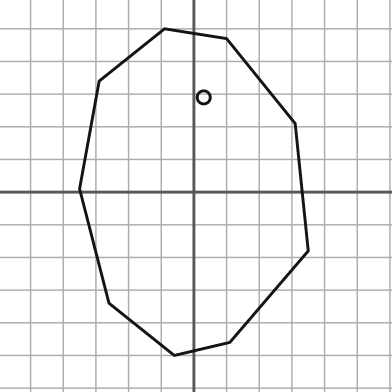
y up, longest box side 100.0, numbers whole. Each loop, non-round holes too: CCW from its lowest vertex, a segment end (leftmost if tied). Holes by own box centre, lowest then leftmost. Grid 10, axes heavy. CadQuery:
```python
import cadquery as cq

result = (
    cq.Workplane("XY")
    .moveTo(-6.0, -50.0)
    .lineTo(11.0, -46.0)
    .lineTo(35.0, -18.0)
    .lineTo(31.0, 21.0)
    .lineTo(10.0, 47.0)
    .lineTo(-9.0, 50.0)
    .lineTo(-29.0, 34.0)
    .lineTo(-35.0, 1.0)
    .lineTo(-26.0, -34.0)
    .close()
    .moveTo(3.0, 29.0)
    .circle(2.0)
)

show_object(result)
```